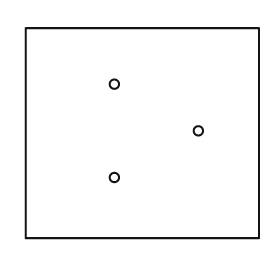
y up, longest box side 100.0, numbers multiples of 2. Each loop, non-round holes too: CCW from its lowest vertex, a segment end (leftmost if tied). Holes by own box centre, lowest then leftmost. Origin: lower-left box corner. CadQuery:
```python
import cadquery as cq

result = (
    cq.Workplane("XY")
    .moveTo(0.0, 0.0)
    .lineTo(100.0, 0.0)
    .lineTo(100.0, 90.0)
    .lineTo(0.0, 90.0)
    .close()
    .moveTo(38.0, 26.0)
    .circle(2.0)
    .moveTo(74.0, 46.0)
    .circle(2.0)
    .moveTo(38.0, 66.0)
    .circle(2.0)
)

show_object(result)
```